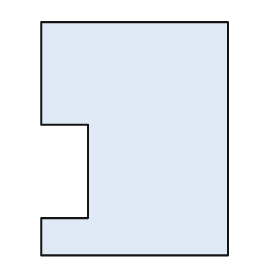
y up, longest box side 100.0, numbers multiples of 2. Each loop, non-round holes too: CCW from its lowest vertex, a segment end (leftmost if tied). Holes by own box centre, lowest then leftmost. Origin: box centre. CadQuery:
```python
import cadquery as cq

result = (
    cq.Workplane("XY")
    .moveTo(-40.0, -50.0)
    .lineTo(40.0, -50.0)
    .lineTo(40.0, 50.0)
    .lineTo(-40.0, 50.0)
    .lineTo(-40.0, 6.0)
    .lineTo(-20.0, 6.0)
    .lineTo(-20.0, -34.0)
    .lineTo(-40.0, -34.0)
    .close()
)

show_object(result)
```